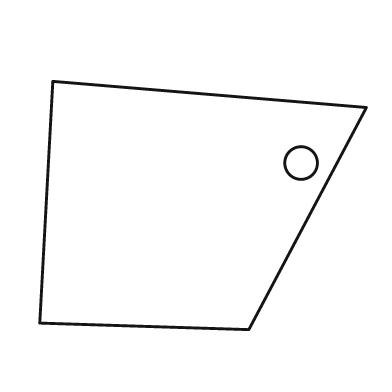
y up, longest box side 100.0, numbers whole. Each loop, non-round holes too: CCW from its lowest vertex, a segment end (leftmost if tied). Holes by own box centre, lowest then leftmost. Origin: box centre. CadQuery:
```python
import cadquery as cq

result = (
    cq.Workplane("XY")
    .moveTo(14.0, -38.0)
    .lineTo(50.0, 30.0)
    .lineTo(-46.0, 38.0)
    .lineTo(-50.0, -36.0)
    .close()
    .moveTo(30.0, 13.0)
    .circle(5.0)
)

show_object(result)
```